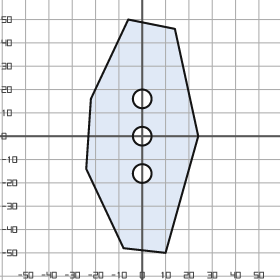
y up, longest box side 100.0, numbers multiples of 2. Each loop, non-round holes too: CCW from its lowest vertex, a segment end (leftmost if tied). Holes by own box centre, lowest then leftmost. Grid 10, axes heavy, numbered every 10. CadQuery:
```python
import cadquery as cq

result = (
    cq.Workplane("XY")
    .moveTo(10.0, -50.0)
    .lineTo(24.0, 0.0)
    .lineTo(14.0, 46.0)
    .lineTo(-6.0, 50.0)
    .lineTo(-22.0, 16.0)
    .lineTo(-24.0, -14.0)
    .lineTo(-8.0, -48.0)
    .close()
    .moveTo(0.0, -16.0)
    .circle(4.0)
    .moveTo(0.0, 0.0)
    .circle(4.0)
    .moveTo(0.0, 16.0)
    .circle(4.0)
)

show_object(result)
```